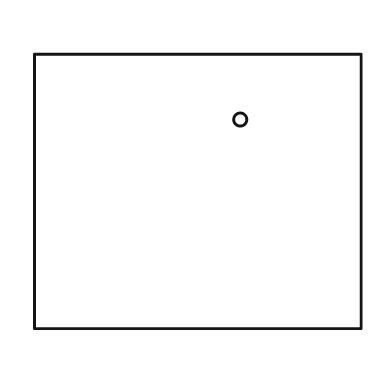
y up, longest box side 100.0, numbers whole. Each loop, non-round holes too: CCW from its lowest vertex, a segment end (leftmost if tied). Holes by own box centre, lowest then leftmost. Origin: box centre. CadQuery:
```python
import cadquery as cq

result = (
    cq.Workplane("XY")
    .moveTo(-50.0, -42.0)
    .lineTo(50.0, -42.0)
    .lineTo(50.0, 42.0)
    .lineTo(-50.0, 42.0)
    .close()
    .moveTo(13.0, 22.0)
    .circle(2.0)
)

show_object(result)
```